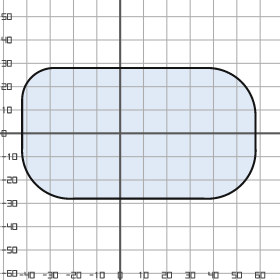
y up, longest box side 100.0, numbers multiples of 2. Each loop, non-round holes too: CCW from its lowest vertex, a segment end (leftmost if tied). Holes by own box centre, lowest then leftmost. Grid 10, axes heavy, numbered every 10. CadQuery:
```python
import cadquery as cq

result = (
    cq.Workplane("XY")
    .moveTo(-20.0, -28.0)
    .lineTo(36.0, -28.0)
    .threePointArc((52.0, -22.0), (58.0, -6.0))
    .lineTo(58.0, 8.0)
    .threePointArc((52.0, 22.0), (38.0, 28.0))
    .lineTo(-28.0, 28.0)
    .threePointArc((-38.0, 24.0), (-42.0, 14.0))
    .lineTo(-42.0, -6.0)
    .threePointArc((-36.0, -22.0), (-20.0, -28.0))
    .close()
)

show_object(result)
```